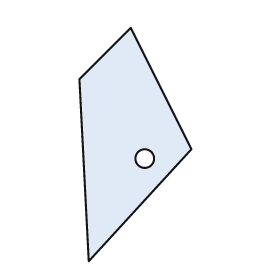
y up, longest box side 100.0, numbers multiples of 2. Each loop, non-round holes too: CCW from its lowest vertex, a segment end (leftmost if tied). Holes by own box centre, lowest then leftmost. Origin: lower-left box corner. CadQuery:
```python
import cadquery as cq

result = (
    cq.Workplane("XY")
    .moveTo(4.0, 0.0)
    .lineTo(48.0, 48.0)
    .lineTo(22.0, 100.0)
    .lineTo(0.0, 78.0)
    .close()
    .moveTo(28.0, 44.0)
    .circle(4.0)
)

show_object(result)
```